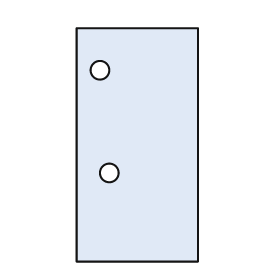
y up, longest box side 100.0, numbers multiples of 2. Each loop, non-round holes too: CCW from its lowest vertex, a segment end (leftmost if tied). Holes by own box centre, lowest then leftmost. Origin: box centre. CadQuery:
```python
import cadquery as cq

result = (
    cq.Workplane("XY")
    .moveTo(-26.0, -50.0)
    .lineTo(26.0, -50.0)
    .lineTo(26.0, 50.0)
    .lineTo(-26.0, 50.0)
    .close()
    .moveTo(-12.0, -12.0)
    .circle(4.0)
    .moveTo(-16.0, 32.0)
    .circle(4.0)
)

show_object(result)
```